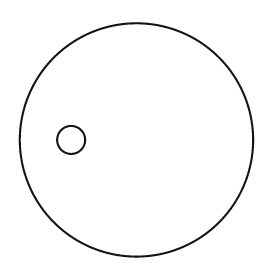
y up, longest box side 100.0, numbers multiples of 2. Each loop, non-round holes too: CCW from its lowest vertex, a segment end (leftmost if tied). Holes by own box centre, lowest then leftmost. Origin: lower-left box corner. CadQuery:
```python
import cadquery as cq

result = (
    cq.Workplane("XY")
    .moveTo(50.0, 50.0)
    .circle(50.0)
    .moveTo(22.0, 50.0)
    .circle(6.0)
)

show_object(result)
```